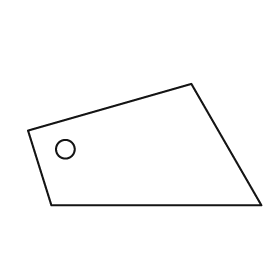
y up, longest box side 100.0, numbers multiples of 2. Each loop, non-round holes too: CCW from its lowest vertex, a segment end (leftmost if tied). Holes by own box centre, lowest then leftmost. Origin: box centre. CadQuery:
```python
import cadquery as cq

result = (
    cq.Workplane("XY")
    .moveTo(-40.0, -26.0)
    .lineTo(50.0, -26.0)
    .lineTo(20.0, 26.0)
    .lineTo(-50.0, 6.0)
    .close()
    .moveTo(-34.0, -2.0)
    .circle(4.0)
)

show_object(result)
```